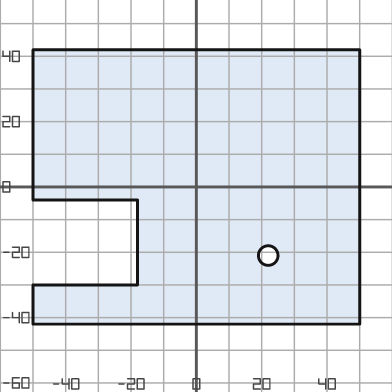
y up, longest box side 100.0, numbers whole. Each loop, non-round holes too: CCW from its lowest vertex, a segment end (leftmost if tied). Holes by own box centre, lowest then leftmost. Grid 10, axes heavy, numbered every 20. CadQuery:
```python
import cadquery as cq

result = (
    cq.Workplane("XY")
    .moveTo(-50.0, -42.0)
    .lineTo(50.0, -42.0)
    .lineTo(50.0, 42.0)
    .lineTo(-50.0, 42.0)
    .lineTo(-50.0, -4.0)
    .lineTo(-18.0, -4.0)
    .lineTo(-18.0, -30.0)
    .lineTo(-50.0, -30.0)
    .close()
    .moveTo(22.0, -21.0)
    .circle(3.0)
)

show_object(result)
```